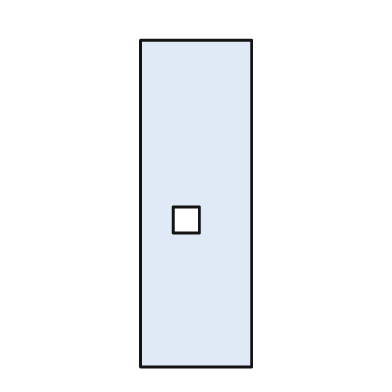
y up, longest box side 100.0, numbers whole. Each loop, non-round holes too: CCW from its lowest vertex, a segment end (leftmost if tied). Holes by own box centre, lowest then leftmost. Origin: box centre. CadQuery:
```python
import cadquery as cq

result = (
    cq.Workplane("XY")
    .moveTo(-17.0, -50.0)
    .lineTo(17.0, -50.0)
    .lineTo(17.0, 50.0)
    .lineTo(-17.0, 50.0)
    .close()
    .moveTo(-7.0, -9.0)
    .lineTo(1.0, -9.0)
    .lineTo(1.0, -1.0)
    .lineTo(-7.0, -1.0)
    .close()
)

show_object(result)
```